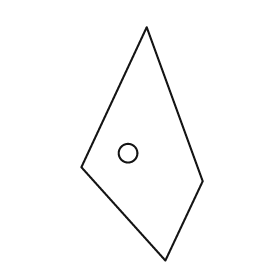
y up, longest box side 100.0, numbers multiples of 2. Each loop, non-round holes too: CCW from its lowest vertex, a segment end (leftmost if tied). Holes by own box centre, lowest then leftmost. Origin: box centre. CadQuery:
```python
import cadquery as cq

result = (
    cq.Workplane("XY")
    .moveTo(10.0, -50.0)
    .lineTo(26.0, -16.0)
    .lineTo(2.0, 50.0)
    .lineTo(-26.0, -10.0)
    .close()
    .moveTo(-6.0, -4.0)
    .circle(4.0)
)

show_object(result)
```